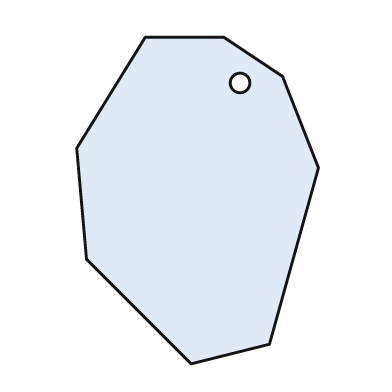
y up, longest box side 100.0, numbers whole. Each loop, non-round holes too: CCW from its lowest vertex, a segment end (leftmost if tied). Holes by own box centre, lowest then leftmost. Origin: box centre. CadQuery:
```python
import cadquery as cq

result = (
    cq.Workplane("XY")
    .moveTo(-2.0, -50.0)
    .lineTo(22.0, -44.0)
    .lineTo(37.0, 10.0)
    .lineTo(26.0, 38.0)
    .lineTo(8.0, 50.0)
    .lineTo(-16.0, 50.0)
    .lineTo(-37.0, 16.0)
    .lineTo(-34.0, -18.0)
    .close()
    .moveTo(13.0, 36.0)
    .circle(3.0)
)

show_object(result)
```